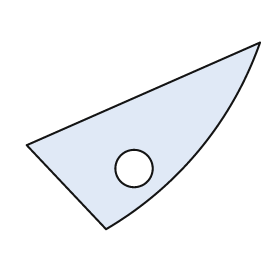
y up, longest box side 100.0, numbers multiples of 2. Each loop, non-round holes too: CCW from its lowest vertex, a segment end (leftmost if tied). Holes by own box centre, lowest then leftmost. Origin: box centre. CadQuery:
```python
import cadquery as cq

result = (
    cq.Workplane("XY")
    .moveTo(-16.0, -40.0)
    .threePointArc((24.0, -6.0), (50.0, 40.0))
    .lineTo(-50.0, -4.0)
    .close()
    .moveTo(-4.0, -14.0)
    .circle(8.0)
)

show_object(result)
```